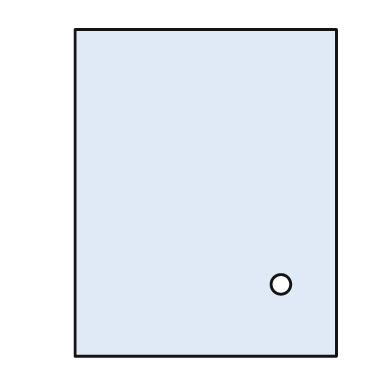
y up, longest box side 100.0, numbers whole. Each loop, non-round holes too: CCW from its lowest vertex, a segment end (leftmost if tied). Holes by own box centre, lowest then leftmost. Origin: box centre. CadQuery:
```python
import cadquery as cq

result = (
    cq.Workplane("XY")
    .moveTo(-40.0, -50.0)
    .lineTo(40.0, -50.0)
    .lineTo(40.0, 50.0)
    .lineTo(-40.0, 50.0)
    .close()
    .moveTo(23.0, -28.0)
    .circle(3.0)
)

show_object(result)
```